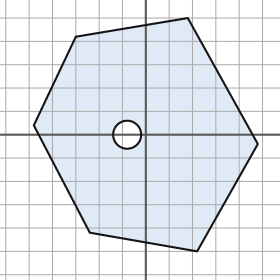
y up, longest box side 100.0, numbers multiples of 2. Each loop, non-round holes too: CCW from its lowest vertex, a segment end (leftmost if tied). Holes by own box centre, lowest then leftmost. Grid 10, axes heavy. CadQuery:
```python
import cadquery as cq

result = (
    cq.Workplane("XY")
    .moveTo(22.0, -50.0)
    .lineTo(48.0, -4.0)
    .lineTo(18.0, 50.0)
    .lineTo(-30.0, 42.0)
    .lineTo(-48.0, 4.0)
    .lineTo(-24.0, -42.0)
    .close()
    .moveTo(-8.0, 0.0)
    .circle(6.0)
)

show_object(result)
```